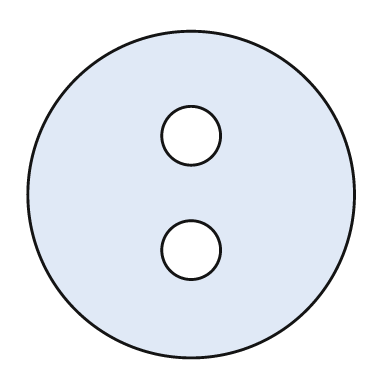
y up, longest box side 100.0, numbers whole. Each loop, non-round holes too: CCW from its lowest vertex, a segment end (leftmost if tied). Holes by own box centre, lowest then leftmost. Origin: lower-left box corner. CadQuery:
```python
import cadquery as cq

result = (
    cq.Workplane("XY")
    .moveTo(50.0, 50.0)
    .circle(50.0)
    .moveTo(50.0, 33.0)
    .circle(9.0)
    .moveTo(50.0, 68.0)
    .circle(9.0)
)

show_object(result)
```